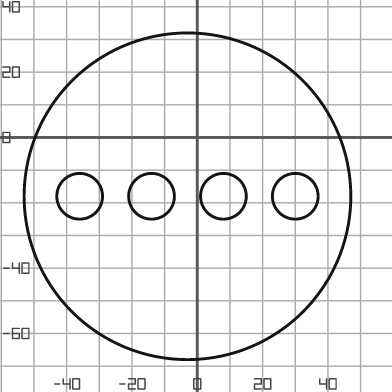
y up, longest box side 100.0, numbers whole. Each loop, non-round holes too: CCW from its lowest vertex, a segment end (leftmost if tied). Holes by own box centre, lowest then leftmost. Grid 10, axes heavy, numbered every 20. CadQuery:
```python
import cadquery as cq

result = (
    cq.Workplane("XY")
    .moveTo(-3.0, -18.0)
    .circle(50.0)
    .moveTo(-36.0, -18.0)
    .circle(7.0)
    .moveTo(-14.0, -18.0)
    .circle(7.0)
    .moveTo(8.0, -18.0)
    .circle(7.0)
    .moveTo(30.0, -18.0)
    .circle(7.0)
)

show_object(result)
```